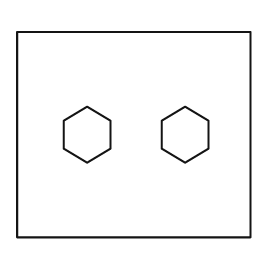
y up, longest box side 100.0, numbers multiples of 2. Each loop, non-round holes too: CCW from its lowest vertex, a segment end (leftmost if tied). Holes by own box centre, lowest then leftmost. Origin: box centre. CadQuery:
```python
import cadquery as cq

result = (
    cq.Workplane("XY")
    .moveTo(-50.0, -44.0)
    .lineTo(50.0, -44.0)
    .lineTo(50.0, 44.0)
    .lineTo(-50.0, 44.0)
    .close()
    .moveTo(-20.0, -12.0)
    .lineTo(-10.0, -6.0)
    .lineTo(-10.0, 6.0)
    .lineTo(-20.0, 12.0)
    .lineTo(-30.0, 6.0)
    .lineTo(-30.0, -6.0)
    .close()
    .moveTo(22.0, -12.0)
    .lineTo(32.0, -6.0)
    .lineTo(32.0, 6.0)
    .lineTo(22.0, 12.0)
    .lineTo(12.0, 6.0)
    .lineTo(12.0, -6.0)
    .close()
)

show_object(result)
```